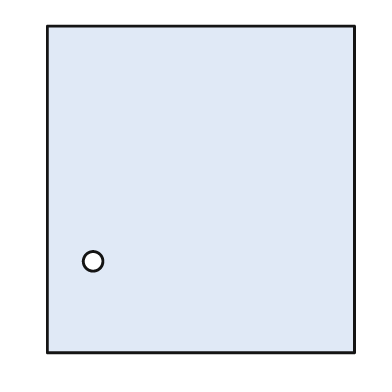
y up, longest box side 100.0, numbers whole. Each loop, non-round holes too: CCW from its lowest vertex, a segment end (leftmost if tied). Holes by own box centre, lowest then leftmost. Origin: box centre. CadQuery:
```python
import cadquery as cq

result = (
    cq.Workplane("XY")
    .moveTo(-47.0, -50.0)
    .lineTo(47.0, -50.0)
    .lineTo(47.0, 50.0)
    .lineTo(-47.0, 50.0)
    .close()
    .moveTo(-33.0, -22.0)
    .circle(3.0)
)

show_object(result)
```